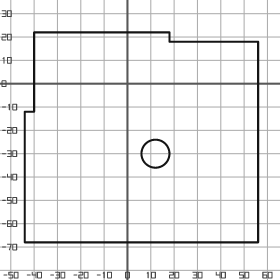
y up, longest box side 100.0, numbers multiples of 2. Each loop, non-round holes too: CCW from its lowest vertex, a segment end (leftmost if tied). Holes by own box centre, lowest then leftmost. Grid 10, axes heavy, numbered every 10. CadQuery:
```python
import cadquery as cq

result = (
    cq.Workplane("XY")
    .moveTo(-44.0, -68.0)
    .lineTo(56.0, -68.0)
    .lineTo(56.0, 18.0)
    .lineTo(18.0, 18.0)
    .lineTo(18.0, 22.0)
    .lineTo(-40.0, 22.0)
    .lineTo(-40.0, -12.0)
    .lineTo(-44.0, -12.0)
    .close()
    .moveTo(12.0, -30.0)
    .circle(6.0)
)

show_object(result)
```